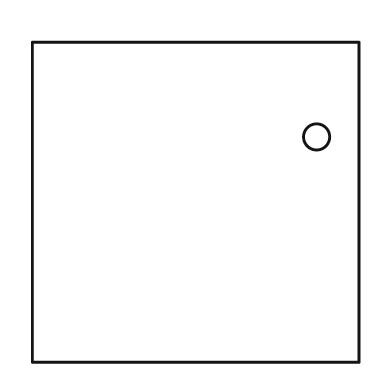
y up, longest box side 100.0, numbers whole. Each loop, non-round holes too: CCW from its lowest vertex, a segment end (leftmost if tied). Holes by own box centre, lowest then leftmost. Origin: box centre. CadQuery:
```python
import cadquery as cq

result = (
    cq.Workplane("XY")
    .moveTo(-50.0, -49.0)
    .lineTo(50.0, -49.0)
    .lineTo(50.0, 49.0)
    .lineTo(-50.0, 49.0)
    .close()
    .moveTo(37.0, 20.0)
    .circle(4.0)
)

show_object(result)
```